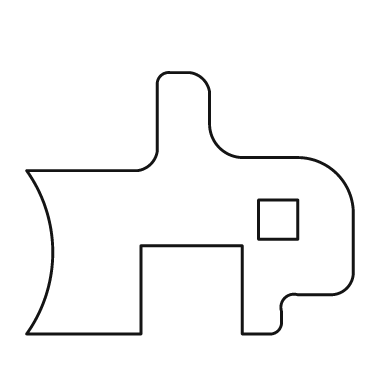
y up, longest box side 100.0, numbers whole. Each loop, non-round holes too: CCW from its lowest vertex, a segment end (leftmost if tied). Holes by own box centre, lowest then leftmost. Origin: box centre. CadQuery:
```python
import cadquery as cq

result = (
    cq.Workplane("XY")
    .moveTo(-50.0, -40.0)
    .lineTo(-15.0, -40.0)
    .lineTo(-15.0, -13.0)
    .lineTo(16.0, -13.0)
    .lineTo(16.0, -40.0)
    .lineTo(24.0, -40.0)
    .threePointArc((27.0, -39.0), (28.0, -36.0))
    .lineTo(28.0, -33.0)
    .threePointArc((29.0, -29.0), (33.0, -28.0))
    .lineTo(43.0, -28.0)
    .threePointArc((48.0, -26.0), (50.0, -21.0))
    .lineTo(50.0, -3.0)
    .threePointArc((45.0, 9.0), (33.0, 14.0))
    .lineTo(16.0, 14.0)
    .threePointArc((9.0, 17.0), (6.0, 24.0))
    .lineTo(6.0, 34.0)
    .threePointArc((4.0, 38.0), (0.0, 40.0))
    .lineTo(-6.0, 40.0)
    .threePointArc((-9.0, 39.0), (-10.0, 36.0))
    .lineTo(-10.0, 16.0)
    .threePointArc((-12.0, 12.0), (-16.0, 10.0))
    .lineTo(-50.0, 10.0)
    .threePointArc((-42.0, -15.0), (-50.0, -40.0))
    .close()
    .moveTo(21.0, -11.0)
    .lineTo(33.0, -11.0)
    .lineTo(33.0, 1.0)
    .lineTo(21.0, 1.0)
    .close()
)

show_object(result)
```